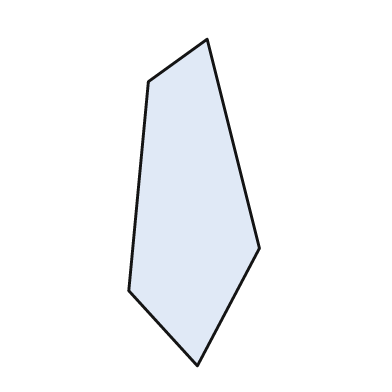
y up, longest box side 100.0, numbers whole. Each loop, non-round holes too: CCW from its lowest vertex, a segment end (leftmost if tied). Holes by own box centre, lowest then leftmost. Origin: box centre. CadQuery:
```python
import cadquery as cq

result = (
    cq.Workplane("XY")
    .moveTo(1.0, -50.0)
    .lineTo(20.0, -14.0)
    .lineTo(4.0, 50.0)
    .lineTo(-14.0, 37.0)
    .lineTo(-20.0, -27.0)
    .close()
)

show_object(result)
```